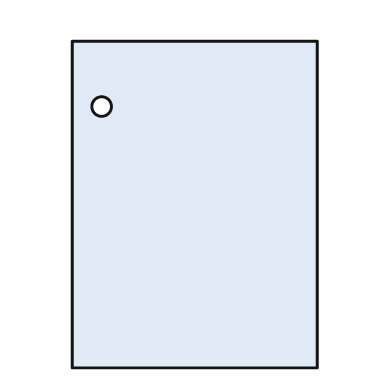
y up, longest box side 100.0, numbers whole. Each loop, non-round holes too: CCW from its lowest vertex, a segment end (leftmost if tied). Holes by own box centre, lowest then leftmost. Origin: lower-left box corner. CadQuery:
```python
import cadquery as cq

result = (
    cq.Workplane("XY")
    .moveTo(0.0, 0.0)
    .lineTo(75.0, 0.0)
    .lineTo(75.0, 100.0)
    .lineTo(0.0, 100.0)
    .close()
    .moveTo(9.0, 80.0)
    .circle(3.0)
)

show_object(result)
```